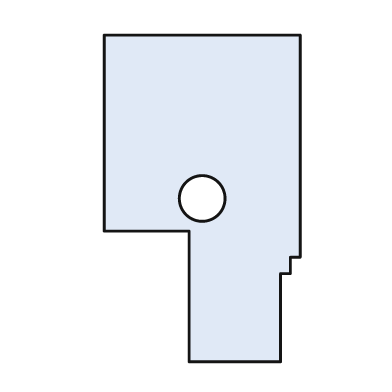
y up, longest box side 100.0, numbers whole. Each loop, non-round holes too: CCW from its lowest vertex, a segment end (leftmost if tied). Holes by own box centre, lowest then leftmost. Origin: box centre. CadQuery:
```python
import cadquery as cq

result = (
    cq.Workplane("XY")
    .moveTo(-4.0, -50.0)
    .lineTo(24.0, -50.0)
    .lineTo(24.0, -23.0)
    .lineTo(27.0, -23.0)
    .lineTo(27.0, -18.0)
    .lineTo(30.0, -18.0)
    .lineTo(30.0, 50.0)
    .lineTo(-30.0, 50.0)
    .lineTo(-30.0, -10.0)
    .lineTo(-4.0, -10.0)
    .close()
    .moveTo(0.0, 0.0)
    .circle(7.0)
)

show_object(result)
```